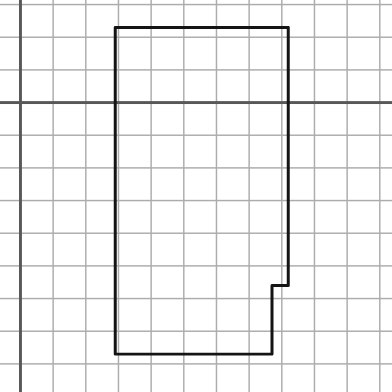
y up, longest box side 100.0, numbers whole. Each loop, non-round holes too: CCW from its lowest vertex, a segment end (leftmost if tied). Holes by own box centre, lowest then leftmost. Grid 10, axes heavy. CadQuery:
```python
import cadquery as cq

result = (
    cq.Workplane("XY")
    .moveTo(29.0, -77.0)
    .lineTo(77.0, -77.0)
    .lineTo(77.0, -56.0)
    .lineTo(82.0, -56.0)
    .lineTo(82.0, 23.0)
    .lineTo(29.0, 23.0)
    .close()
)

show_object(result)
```